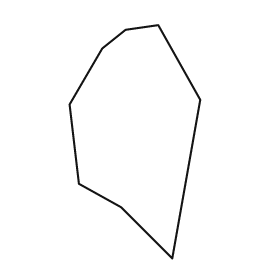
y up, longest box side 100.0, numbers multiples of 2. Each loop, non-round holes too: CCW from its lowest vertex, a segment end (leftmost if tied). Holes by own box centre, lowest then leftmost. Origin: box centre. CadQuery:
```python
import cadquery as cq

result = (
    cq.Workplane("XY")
    .moveTo(16.0, -50.0)
    .lineTo(28.0, 18.0)
    .lineTo(10.0, 50.0)
    .lineTo(-4.0, 48.0)
    .lineTo(-14.0, 40.0)
    .lineTo(-28.0, 16.0)
    .lineTo(-24.0, -18.0)
    .lineTo(-6.0, -28.0)
    .close()
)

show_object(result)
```